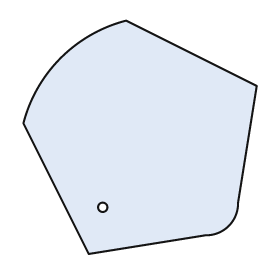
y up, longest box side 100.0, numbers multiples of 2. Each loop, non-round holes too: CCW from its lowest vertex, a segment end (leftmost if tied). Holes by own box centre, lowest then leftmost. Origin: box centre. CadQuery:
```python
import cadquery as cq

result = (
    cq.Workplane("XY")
    .moveTo(-22.0, -50.0)
    .lineTo(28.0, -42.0)
    .threePointArc((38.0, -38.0), (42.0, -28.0))
    .lineTo(50.0, 22.0)
    .lineTo(-6.0, 50.0)
    .threePointArc((-34.0, 34.0), (-50.0, 6.0))
    .close()
    .moveTo(-16.0, -30.0)
    .circle(2.0)
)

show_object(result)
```